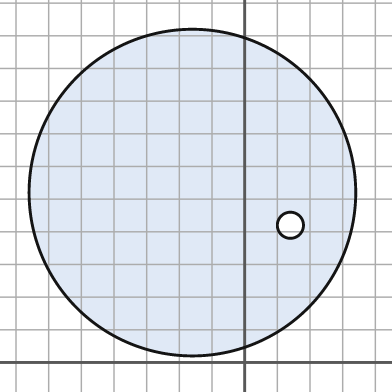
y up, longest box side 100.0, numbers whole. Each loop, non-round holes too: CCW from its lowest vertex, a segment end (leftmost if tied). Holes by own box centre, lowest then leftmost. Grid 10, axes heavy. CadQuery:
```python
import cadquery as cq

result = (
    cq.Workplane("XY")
    .moveTo(-16.0, 52.0)
    .circle(50.0)
    .moveTo(14.0, 42.0)
    .circle(4.0)
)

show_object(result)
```